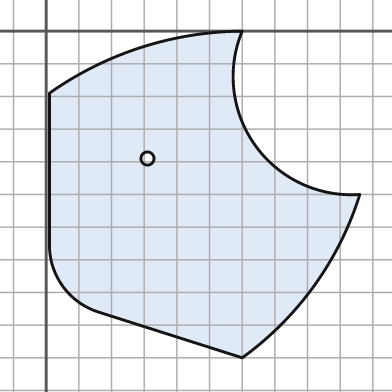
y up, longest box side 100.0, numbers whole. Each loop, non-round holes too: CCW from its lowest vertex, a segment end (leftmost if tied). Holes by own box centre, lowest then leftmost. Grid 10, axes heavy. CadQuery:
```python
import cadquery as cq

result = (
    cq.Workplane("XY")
    .moveTo(60.0, -100.0)
    .threePointArc((82.0, -78.0), (96.0, -50.0))
    .threePointArc((64.0, -35.0), (60.0, 0.0))
    .threePointArc((29.0, -5.0), (1.0, -19.0))
    .lineTo(1.0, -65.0)
    .threePointArc((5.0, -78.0), (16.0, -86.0))
    .close()
    .moveTo(31.0, -39.0)
    .circle(2.0)
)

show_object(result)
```